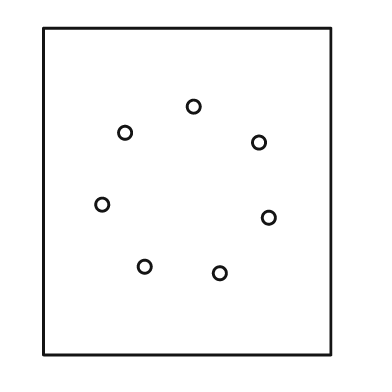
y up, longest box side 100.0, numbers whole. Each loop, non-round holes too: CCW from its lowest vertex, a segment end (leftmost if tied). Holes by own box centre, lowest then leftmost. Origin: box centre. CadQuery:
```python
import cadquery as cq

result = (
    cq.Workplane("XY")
    .moveTo(-44.0, -50.0)
    .lineTo(44.0, -50.0)
    .lineTo(44.0, 50.0)
    .lineTo(-44.0, 50.0)
    .close()
    .moveTo(10.0, -25.0)
    .circle(2.0)
    .moveTo(-13.0, -23.0)
    .circle(2.0)
    .moveTo(25.0, -8.0)
    .circle(2.0)
    .moveTo(-26.0, -4.0)
    .circle(2.0)
    .moveTo(22.0, 15.0)
    .circle(2.0)
    .moveTo(-19.0, 18.0)
    .circle(2.0)
    .moveTo(2.0, 26.0)
    .circle(2.0)
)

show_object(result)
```